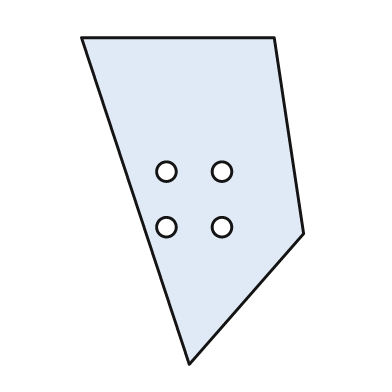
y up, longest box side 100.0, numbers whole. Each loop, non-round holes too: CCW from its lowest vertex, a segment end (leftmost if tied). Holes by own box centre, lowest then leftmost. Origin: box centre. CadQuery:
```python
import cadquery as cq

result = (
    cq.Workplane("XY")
    .moveTo(-1.0, -50.0)
    .lineTo(34.0, -10.0)
    .lineTo(25.0, 50.0)
    .lineTo(-34.0, 50.0)
    .close()
    .moveTo(-8.0, -8.0)
    .circle(3.0)
    .moveTo(9.0, -8.0)
    .circle(3.0)
    .moveTo(-8.0, 9.0)
    .circle(3.0)
    .moveTo(9.0, 9.0)
    .circle(3.0)
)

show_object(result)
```